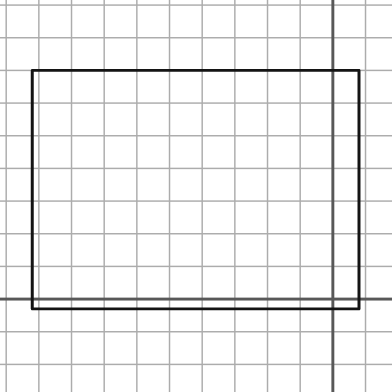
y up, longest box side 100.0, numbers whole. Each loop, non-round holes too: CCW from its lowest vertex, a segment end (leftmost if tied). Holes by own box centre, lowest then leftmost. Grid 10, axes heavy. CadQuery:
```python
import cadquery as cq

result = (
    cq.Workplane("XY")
    .moveTo(-92.0, -3.0)
    .lineTo(8.0, -3.0)
    .lineTo(8.0, 70.0)
    .lineTo(-92.0, 70.0)
    .close()
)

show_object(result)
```